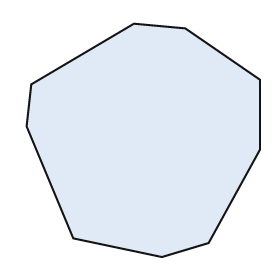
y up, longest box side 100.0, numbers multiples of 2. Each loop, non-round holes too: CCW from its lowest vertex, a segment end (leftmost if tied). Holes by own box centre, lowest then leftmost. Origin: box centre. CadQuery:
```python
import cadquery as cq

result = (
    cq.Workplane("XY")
    .moveTo(8.0, -50.0)
    .lineTo(28.0, -44.0)
    .lineTo(50.0, -4.0)
    .lineTo(50.0, 26.0)
    .lineTo(18.0, 48.0)
    .lineTo(-4.0, 50.0)
    .lineTo(-48.0, 24.0)
    .lineTo(-50.0, 6.0)
    .lineTo(-30.0, -42.0)
    .close()
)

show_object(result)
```